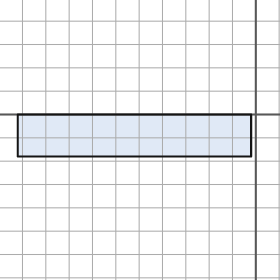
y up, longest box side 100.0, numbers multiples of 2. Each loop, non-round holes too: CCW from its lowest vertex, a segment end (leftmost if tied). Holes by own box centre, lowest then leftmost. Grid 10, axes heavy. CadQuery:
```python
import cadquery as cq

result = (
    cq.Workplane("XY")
    .moveTo(-102.0, -18.0)
    .lineTo(-2.0, -18.0)
    .lineTo(-2.0, 0.0)
    .lineTo(-102.0, 0.0)
    .close()
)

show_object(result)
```